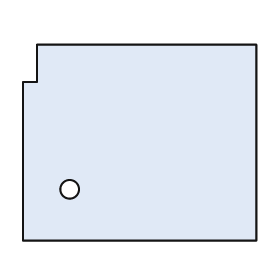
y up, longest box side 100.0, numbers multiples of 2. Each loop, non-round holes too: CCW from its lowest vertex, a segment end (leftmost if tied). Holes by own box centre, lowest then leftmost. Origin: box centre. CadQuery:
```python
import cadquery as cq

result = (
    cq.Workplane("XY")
    .moveTo(-50.0, -42.0)
    .lineTo(50.0, -42.0)
    .lineTo(50.0, 42.0)
    .lineTo(-44.0, 42.0)
    .lineTo(-44.0, 26.0)
    .lineTo(-50.0, 26.0)
    .close()
    .moveTo(-30.0, -20.0)
    .circle(4.0)
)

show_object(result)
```